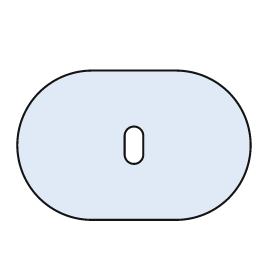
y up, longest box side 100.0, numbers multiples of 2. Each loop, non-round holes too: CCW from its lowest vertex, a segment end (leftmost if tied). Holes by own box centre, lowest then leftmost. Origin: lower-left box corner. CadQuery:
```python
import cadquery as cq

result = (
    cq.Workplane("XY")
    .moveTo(32.0, 0.0)
    .lineTo(68.0, 0.0)
    .threePointArc((100.0, 32.0), (68.0, 64.0))
    .lineTo(32.0, 64.0)
    .threePointArc((0.0, 32.0), (32.0, 0.0))
    .close()
    .moveTo(46.0, 28.0)
    .threePointArc((50.0, 24.0), (54.0, 28.0))
    .lineTo(54.0, 36.0)
    .threePointArc((50.0, 40.0), (46.0, 36.0))
    .close()
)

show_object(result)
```